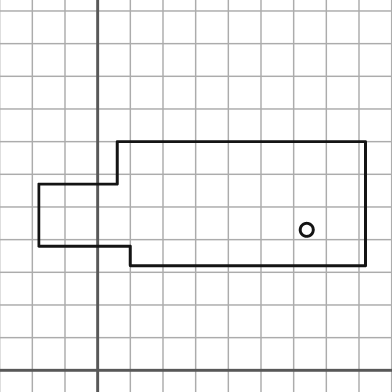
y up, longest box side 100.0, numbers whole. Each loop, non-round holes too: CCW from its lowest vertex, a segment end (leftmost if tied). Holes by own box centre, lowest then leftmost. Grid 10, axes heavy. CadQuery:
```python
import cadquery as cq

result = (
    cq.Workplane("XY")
    .moveTo(10.0, 32.0)
    .lineTo(82.0, 32.0)
    .lineTo(82.0, 70.0)
    .lineTo(6.0, 70.0)
    .lineTo(6.0, 57.0)
    .lineTo(-18.0, 57.0)
    .lineTo(-18.0, 38.0)
    .lineTo(10.0, 38.0)
    .close()
    .moveTo(64.0, 43.0)
    .circle(2.0)
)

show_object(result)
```